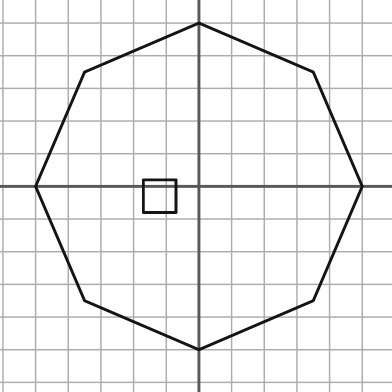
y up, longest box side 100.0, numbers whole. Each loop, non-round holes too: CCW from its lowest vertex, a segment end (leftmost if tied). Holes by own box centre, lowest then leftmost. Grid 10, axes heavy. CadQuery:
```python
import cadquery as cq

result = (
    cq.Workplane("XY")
    .moveTo(0.0, -50.0)
    .lineTo(35.0, -35.0)
    .lineTo(50.0, 0.0)
    .lineTo(35.0, 35.0)
    .lineTo(0.0, 50.0)
    .lineTo(-35.0, 35.0)
    .lineTo(-50.0, 0.0)
    .lineTo(-35.0, -35.0)
    .close()
    .moveTo(-17.0, -8.0)
    .lineTo(-7.0, -8.0)
    .lineTo(-7.0, 2.0)
    .lineTo(-17.0, 2.0)
    .close()
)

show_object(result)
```